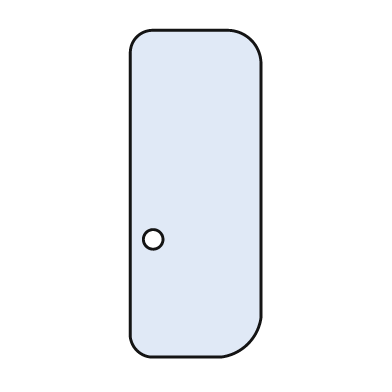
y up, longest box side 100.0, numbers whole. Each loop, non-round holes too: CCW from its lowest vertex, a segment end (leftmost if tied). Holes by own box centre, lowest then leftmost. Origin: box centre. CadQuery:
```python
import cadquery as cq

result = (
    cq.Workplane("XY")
    .moveTo(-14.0, -50.0)
    .lineTo(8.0, -50.0)
    .threePointArc((16.0, -46.0), (20.0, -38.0))
    .lineTo(20.0, 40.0)
    .threePointArc((17.0, 47.0), (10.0, 50.0))
    .lineTo(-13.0, 50.0)
    .threePointArc((-18.0, 48.0), (-20.0, 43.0))
    .lineTo(-20.0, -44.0)
    .threePointArc((-18.0, -48.0), (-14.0, -50.0))
    .close()
    .moveTo(-13.0, -14.0)
    .circle(3.0)
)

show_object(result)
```